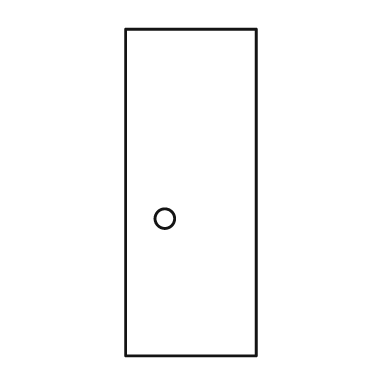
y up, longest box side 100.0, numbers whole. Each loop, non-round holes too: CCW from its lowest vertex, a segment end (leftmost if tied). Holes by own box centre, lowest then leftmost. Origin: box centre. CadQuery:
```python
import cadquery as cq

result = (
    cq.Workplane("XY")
    .moveTo(-20.0, -50.0)
    .lineTo(20.0, -50.0)
    .lineTo(20.0, 50.0)
    .lineTo(-20.0, 50.0)
    .close()
    .moveTo(-8.0, -8.0)
    .circle(3.0)
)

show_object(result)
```